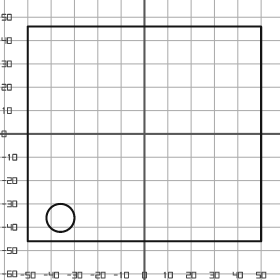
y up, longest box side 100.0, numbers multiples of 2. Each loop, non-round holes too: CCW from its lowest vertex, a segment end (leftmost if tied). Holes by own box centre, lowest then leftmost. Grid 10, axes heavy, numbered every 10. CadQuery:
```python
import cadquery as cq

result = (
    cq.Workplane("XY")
    .moveTo(-50.0, -46.0)
    .lineTo(50.0, -46.0)
    .lineTo(50.0, 46.0)
    .lineTo(-50.0, 46.0)
    .close()
    .moveTo(-36.0, -36.0)
    .circle(6.0)
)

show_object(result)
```